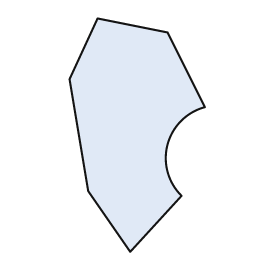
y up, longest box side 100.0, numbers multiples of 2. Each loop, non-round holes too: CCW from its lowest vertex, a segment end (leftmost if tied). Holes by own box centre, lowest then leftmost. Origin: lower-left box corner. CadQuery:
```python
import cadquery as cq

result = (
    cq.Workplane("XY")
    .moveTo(26.0, 0.0)
    .lineTo(48.0, 24.0)
    .threePointArc((42.0, 46.0), (58.0, 62.0))
    .lineTo(42.0, 94.0)
    .lineTo(12.0, 100.0)
    .lineTo(0.0, 74.0)
    .lineTo(8.0, 26.0)
    .close()
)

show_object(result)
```